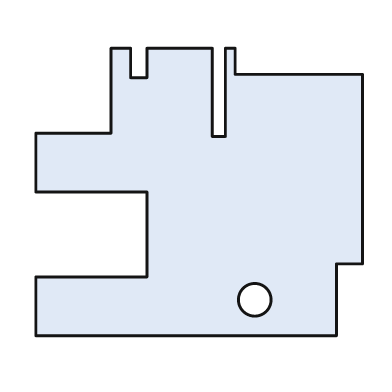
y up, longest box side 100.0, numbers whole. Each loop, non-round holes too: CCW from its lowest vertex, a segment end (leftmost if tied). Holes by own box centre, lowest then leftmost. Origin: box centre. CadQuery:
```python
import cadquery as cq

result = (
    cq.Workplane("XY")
    .moveTo(-50.0, -44.0)
    .lineTo(42.0, -44.0)
    .lineTo(42.0, -22.0)
    .lineTo(50.0, -22.0)
    .lineTo(50.0, 36.0)
    .lineTo(11.0, 36.0)
    .lineTo(11.0, 44.0)
    .lineTo(8.0, 44.0)
    .lineTo(8.0, 17.0)
    .lineTo(4.0, 17.0)
    .lineTo(4.0, 44.0)
    .lineTo(-16.0, 44.0)
    .lineTo(-16.0, 35.0)
    .lineTo(-21.0, 35.0)
    .lineTo(-21.0, 44.0)
    .lineTo(-27.0, 44.0)
    .lineTo(-27.0, 18.0)
    .lineTo(-50.0, 18.0)
    .lineTo(-50.0, 0.0)
    .lineTo(-16.0, 0.0)
    .lineTo(-16.0, -26.0)
    .lineTo(-50.0, -26.0)
    .close()
    .moveTo(17.0, -33.0)
    .circle(5.0)
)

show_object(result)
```